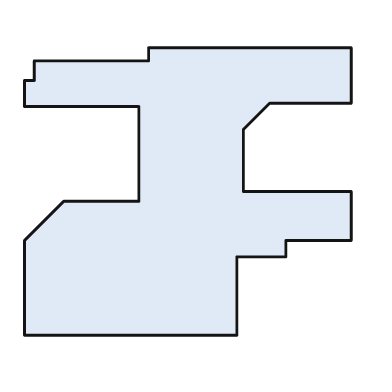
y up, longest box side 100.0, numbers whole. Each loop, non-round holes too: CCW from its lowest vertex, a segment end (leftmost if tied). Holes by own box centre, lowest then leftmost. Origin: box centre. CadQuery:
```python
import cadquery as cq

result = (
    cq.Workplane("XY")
    .moveTo(-50.0, -44.0)
    .lineTo(15.0, -44.0)
    .lineTo(15.0, -20.0)
    .lineTo(30.0, -20.0)
    .lineTo(30.0, -15.0)
    .lineTo(50.0, -15.0)
    .lineTo(50.0, 0.0)
    .lineTo(17.0, 0.0)
    .lineTo(17.0, 19.0)
    .lineTo(25.0, 27.0)
    .lineTo(50.0, 27.0)
    .lineTo(50.0, 44.0)
    .lineTo(-12.0, 44.0)
    .lineTo(-12.0, 40.0)
    .lineTo(-47.0, 40.0)
    .lineTo(-47.0, 34.0)
    .lineTo(-50.0, 34.0)
    .lineTo(-50.0, 26.0)
    .lineTo(-15.0, 26.0)
    .lineTo(-15.0, -3.0)
    .lineTo(-38.0, -3.0)
    .lineTo(-50.0, -15.0)
    .close()
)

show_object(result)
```